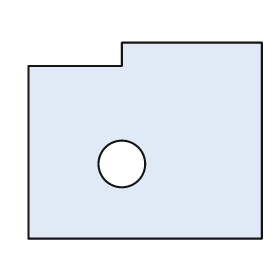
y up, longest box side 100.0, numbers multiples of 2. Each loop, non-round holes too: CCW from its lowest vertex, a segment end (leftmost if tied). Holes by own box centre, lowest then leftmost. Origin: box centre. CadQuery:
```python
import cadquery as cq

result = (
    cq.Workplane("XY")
    .moveTo(-50.0, -42.0)
    .lineTo(50.0, -42.0)
    .lineTo(50.0, 42.0)
    .lineTo(-10.0, 42.0)
    .lineTo(-10.0, 32.0)
    .lineTo(-50.0, 32.0)
    .close()
    .moveTo(-10.0, -10.0)
    .circle(10.0)
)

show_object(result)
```